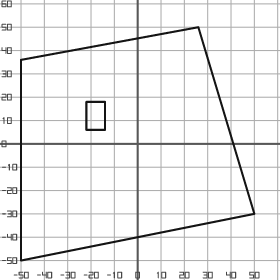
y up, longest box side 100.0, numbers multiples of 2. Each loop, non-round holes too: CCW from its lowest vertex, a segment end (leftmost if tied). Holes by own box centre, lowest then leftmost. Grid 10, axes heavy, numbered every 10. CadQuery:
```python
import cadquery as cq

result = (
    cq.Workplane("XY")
    .moveTo(-50.0, -50.0)
    .lineTo(50.0, -30.0)
    .lineTo(26.0, 50.0)
    .lineTo(-50.0, 36.0)
    .close()
    .moveTo(-22.0, 6.0)
    .lineTo(-14.0, 6.0)
    .lineTo(-14.0, 18.0)
    .lineTo(-22.0, 18.0)
    .close()
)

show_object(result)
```